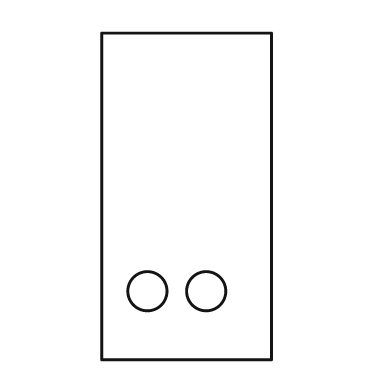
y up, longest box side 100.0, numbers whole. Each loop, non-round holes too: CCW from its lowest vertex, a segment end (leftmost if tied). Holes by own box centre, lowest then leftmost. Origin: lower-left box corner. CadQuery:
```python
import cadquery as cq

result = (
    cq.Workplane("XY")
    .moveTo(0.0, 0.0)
    .lineTo(52.0, 0.0)
    .lineTo(52.0, 100.0)
    .lineTo(0.0, 100.0)
    .close()
    .moveTo(14.0, 21.0)
    .circle(6.0)
    .moveTo(32.0, 21.0)
    .circle(6.0)
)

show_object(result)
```